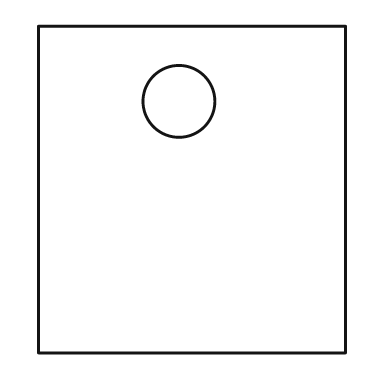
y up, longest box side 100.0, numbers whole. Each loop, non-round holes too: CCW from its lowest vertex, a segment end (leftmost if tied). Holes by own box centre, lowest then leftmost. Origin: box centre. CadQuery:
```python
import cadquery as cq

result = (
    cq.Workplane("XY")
    .moveTo(-47.0, -50.0)
    .lineTo(47.0, -50.0)
    .lineTo(47.0, 50.0)
    .lineTo(-47.0, 50.0)
    .close()
    .moveTo(-4.0, 27.0)
    .circle(11.0)
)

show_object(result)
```